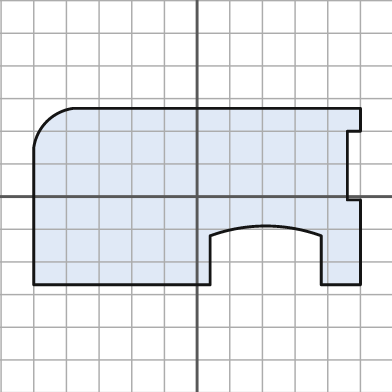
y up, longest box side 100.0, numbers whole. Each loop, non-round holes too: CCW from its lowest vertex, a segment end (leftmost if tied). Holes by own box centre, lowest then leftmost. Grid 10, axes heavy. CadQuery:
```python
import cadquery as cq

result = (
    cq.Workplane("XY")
    .moveTo(-50.0, -27.0)
    .lineTo(4.0, -27.0)
    .lineTo(4.0, -12.0)
    .threePointArc((21.0, -9.0), (38.0, -12.0))
    .lineTo(38.0, -27.0)
    .lineTo(50.0, -27.0)
    .lineTo(50.0, -1.0)
    .lineTo(46.0, -1.0)
    .lineTo(46.0, 20.0)
    .lineTo(50.0, 20.0)
    .lineTo(50.0, 27.0)
    .lineTo(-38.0, 27.0)
    .threePointArc((-46.0, 23.0), (-50.0, 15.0))
    .close()
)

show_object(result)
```